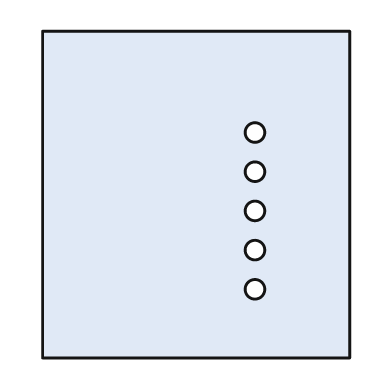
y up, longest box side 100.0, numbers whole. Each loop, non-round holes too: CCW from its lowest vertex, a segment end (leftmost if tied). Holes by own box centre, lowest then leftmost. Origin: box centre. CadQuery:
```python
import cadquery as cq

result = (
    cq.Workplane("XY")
    .moveTo(-47.0, -50.0)
    .lineTo(47.0, -50.0)
    .lineTo(47.0, 50.0)
    .lineTo(-47.0, 50.0)
    .close()
    .moveTo(18.0, -29.0)
    .circle(3.0)
    .moveTo(18.0, -17.0)
    .circle(3.0)
    .moveTo(18.0, -5.0)
    .circle(3.0)
    .moveTo(18.0, 7.0)
    .circle(3.0)
    .moveTo(18.0, 19.0)
    .circle(3.0)
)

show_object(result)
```